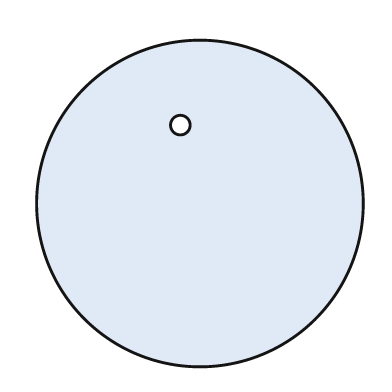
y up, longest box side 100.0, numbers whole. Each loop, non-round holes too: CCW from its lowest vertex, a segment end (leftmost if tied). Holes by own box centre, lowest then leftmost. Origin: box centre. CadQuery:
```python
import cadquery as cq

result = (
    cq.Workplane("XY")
    .moveTo(0.0, 0.0)
    .circle(50.0)
    .moveTo(-6.0, 24.0)
    .circle(3.0)
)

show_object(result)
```